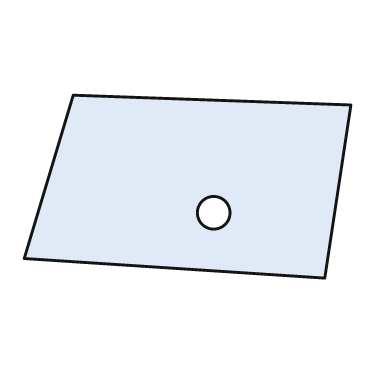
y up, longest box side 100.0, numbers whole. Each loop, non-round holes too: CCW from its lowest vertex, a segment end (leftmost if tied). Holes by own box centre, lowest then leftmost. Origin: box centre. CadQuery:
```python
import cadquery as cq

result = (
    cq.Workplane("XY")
    .moveTo(42.0, -28.0)
    .lineTo(50.0, 25.0)
    .lineTo(-35.0, 28.0)
    .lineTo(-50.0, -22.0)
    .close()
    .moveTo(8.0, -8.0)
    .circle(5.0)
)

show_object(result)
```